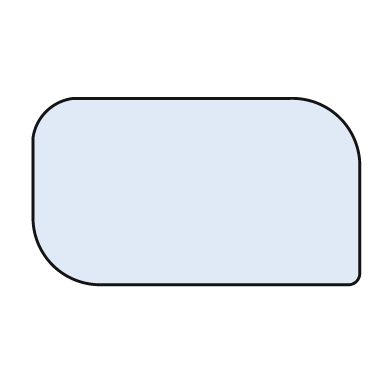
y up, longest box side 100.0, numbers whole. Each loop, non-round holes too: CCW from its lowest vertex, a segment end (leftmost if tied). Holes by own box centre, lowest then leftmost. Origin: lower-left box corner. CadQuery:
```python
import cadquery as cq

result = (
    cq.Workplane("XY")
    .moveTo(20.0, 0.0)
    .lineTo(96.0, 0.0)
    .threePointArc((99.0, 1.0), (100.0, 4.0))
    .lineTo(100.0, 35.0)
    .threePointArc((94.0, 51.0), (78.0, 57.0))
    .lineTo(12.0, 57.0)
    .threePointArc((4.0, 53.0), (0.0, 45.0))
    .lineTo(0.0, 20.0)
    .threePointArc((6.0, 6.0), (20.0, 0.0))
    .close()
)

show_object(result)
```